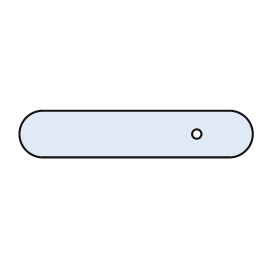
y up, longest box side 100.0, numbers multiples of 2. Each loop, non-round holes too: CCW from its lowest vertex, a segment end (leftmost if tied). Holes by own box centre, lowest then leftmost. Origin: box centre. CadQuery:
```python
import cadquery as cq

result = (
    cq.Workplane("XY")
    .moveTo(-40.0, -10.0)
    .lineTo(40.0, -10.0)
    .threePointArc((50.0, 0.0), (40.0, 10.0))
    .lineTo(-40.0, 10.0)
    .threePointArc((-50.0, 0.0), (-40.0, -10.0))
    .close()
    .moveTo(26.0, 0.0)
    .circle(2.0)
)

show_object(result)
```